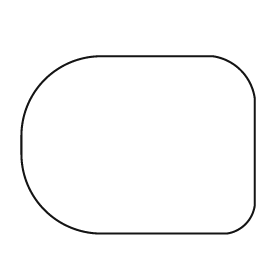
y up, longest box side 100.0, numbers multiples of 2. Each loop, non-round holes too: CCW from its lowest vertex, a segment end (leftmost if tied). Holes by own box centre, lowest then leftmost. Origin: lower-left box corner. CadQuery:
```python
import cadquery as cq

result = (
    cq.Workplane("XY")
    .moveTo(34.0, 0.0)
    .lineTo(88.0, 0.0)
    .threePointArc((96.0, 4.0), (100.0, 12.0))
    .lineTo(100.0, 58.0)
    .threePointArc((94.0, 70.0), (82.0, 76.0))
    .lineTo(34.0, 76.0)
    .threePointArc((10.0, 66.0), (0.0, 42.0))
    .lineTo(0.0, 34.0)
    .threePointArc((10.0, 10.0), (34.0, 0.0))
    .close()
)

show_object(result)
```